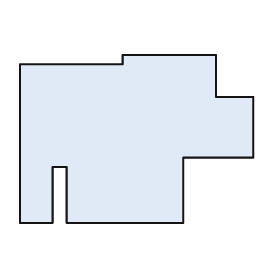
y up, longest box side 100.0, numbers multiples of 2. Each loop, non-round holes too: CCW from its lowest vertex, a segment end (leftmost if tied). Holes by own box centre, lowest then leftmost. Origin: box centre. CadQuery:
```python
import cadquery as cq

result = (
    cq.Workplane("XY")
    .moveTo(-50.0, -36.0)
    .lineTo(-36.0, -36.0)
    .lineTo(-36.0, -12.0)
    .lineTo(-30.0, -12.0)
    .lineTo(-30.0, -36.0)
    .lineTo(20.0, -36.0)
    .lineTo(20.0, -8.0)
    .lineTo(50.0, -8.0)
    .lineTo(50.0, 18.0)
    .lineTo(34.0, 18.0)
    .lineTo(34.0, 36.0)
    .lineTo(-6.0, 36.0)
    .lineTo(-6.0, 32.0)
    .lineTo(-50.0, 32.0)
    .close()
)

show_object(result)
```